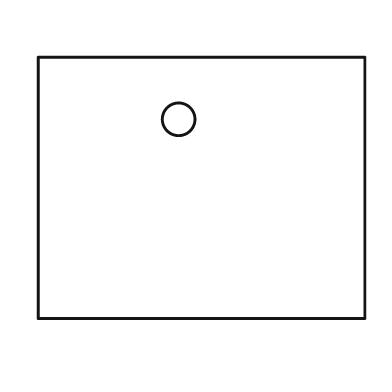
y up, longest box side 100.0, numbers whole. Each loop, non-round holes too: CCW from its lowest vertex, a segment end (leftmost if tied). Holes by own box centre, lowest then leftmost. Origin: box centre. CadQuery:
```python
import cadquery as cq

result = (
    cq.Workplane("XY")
    .moveTo(-50.0, -40.0)
    .lineTo(50.0, -40.0)
    .lineTo(50.0, 40.0)
    .lineTo(-50.0, 40.0)
    .close()
    .moveTo(-7.0, 21.0)
    .circle(5.0)
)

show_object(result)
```